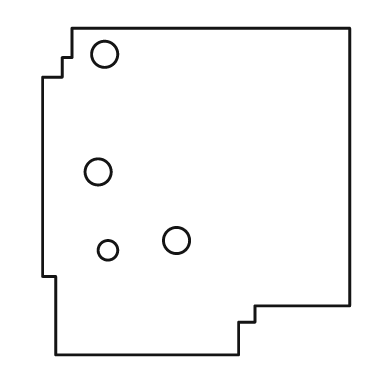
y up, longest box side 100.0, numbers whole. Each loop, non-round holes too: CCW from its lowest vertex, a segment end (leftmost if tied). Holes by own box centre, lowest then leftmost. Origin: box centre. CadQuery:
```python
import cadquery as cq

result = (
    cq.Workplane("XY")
    .moveTo(-43.0, -50.0)
    .lineTo(13.0, -50.0)
    .lineTo(13.0, -40.0)
    .lineTo(18.0, -40.0)
    .lineTo(18.0, -35.0)
    .lineTo(47.0, -35.0)
    .lineTo(47.0, 50.0)
    .lineTo(-38.0, 50.0)
    .lineTo(-38.0, 41.0)
    .lineTo(-41.0, 41.0)
    .lineTo(-41.0, 35.0)
    .lineTo(-47.0, 35.0)
    .lineTo(-47.0, -26.0)
    .lineTo(-43.0, -26.0)
    .close()
    .moveTo(-27.0, -18.0)
    .circle(3.0)
    .moveTo(-6.0, -15.0)
    .circle(4.0)
    .moveTo(-30.0, 6.0)
    .circle(4.0)
    .moveTo(-28.0, 42.0)
    .circle(4.0)
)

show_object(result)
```